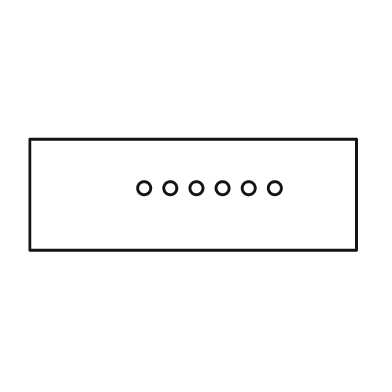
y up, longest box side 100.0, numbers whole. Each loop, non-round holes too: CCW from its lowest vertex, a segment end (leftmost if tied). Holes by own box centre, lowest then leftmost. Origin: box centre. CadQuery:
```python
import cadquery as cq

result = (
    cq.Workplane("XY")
    .moveTo(-50.0, -17.0)
    .lineTo(50.0, -17.0)
    .lineTo(50.0, 17.0)
    .lineTo(-50.0, 17.0)
    .close()
    .moveTo(-15.0, 2.0)
    .circle(2.0)
    .moveTo(-7.0, 2.0)
    .circle(2.0)
    .moveTo(1.0, 2.0)
    .circle(2.0)
    .moveTo(9.0, 2.0)
    .circle(2.0)
    .moveTo(17.0, 2.0)
    .circle(2.0)
    .moveTo(25.0, 2.0)
    .circle(2.0)
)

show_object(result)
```